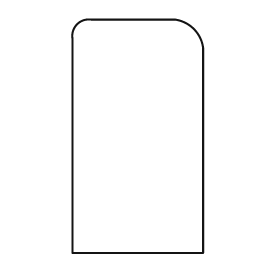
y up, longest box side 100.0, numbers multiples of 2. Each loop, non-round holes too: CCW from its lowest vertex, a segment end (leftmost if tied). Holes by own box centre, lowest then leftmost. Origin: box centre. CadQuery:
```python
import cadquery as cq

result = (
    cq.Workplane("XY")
    .moveTo(-28.0, -50.0)
    .lineTo(28.0, -50.0)
    .lineTo(28.0, 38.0)
    .threePointArc((24.0, 46.0), (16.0, 50.0))
    .lineTo(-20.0, 50.0)
    .threePointArc((-26.0, 48.0), (-28.0, 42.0))
    .close()
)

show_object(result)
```